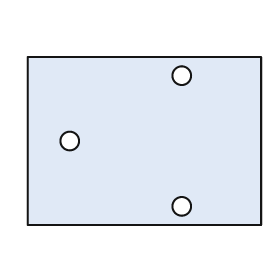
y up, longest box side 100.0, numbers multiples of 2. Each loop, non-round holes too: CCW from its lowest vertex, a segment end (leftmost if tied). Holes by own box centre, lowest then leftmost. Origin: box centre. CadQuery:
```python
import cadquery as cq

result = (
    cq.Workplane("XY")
    .moveTo(-50.0, -36.0)
    .lineTo(50.0, -36.0)
    .lineTo(50.0, 36.0)
    .lineTo(-50.0, 36.0)
    .close()
    .moveTo(16.0, -28.0)
    .circle(4.0)
    .moveTo(-32.0, 0.0)
    .circle(4.0)
    .moveTo(16.0, 28.0)
    .circle(4.0)
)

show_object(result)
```